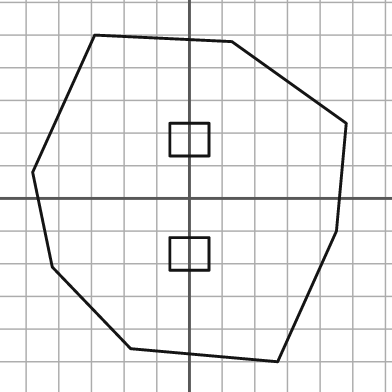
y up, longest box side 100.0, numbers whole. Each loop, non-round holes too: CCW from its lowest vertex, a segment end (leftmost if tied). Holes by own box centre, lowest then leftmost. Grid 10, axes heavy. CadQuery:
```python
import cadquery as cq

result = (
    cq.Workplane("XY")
    .moveTo(27.0, -50.0)
    .lineTo(45.0, -10.0)
    .lineTo(48.0, 23.0)
    .lineTo(13.0, 48.0)
    .lineTo(-29.0, 50.0)
    .lineTo(-48.0, 8.0)
    .lineTo(-42.0, -21.0)
    .lineTo(-18.0, -46.0)
    .close()
    .moveTo(-6.0, -22.0)
    .lineTo(6.0, -22.0)
    .lineTo(6.0, -12.0)
    .lineTo(-6.0, -12.0)
    .close()
    .moveTo(-6.0, 13.0)
    .lineTo(6.0, 13.0)
    .lineTo(6.0, 23.0)
    .lineTo(-6.0, 23.0)
    .close()
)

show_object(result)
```